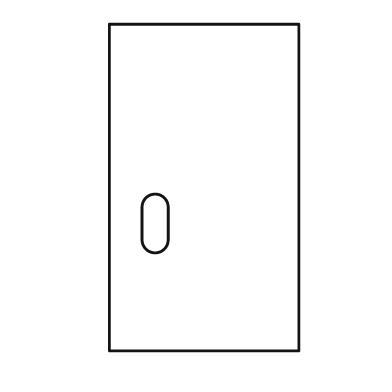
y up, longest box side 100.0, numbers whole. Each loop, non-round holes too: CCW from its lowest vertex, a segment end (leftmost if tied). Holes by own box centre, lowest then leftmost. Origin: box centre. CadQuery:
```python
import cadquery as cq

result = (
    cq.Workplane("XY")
    .moveTo(-29.0, -50.0)
    .lineTo(29.0, -50.0)
    .lineTo(29.0, 50.0)
    .lineTo(-29.0, 50.0)
    .close()
    .moveTo(-19.0, -16.0)
    .threePointArc((-15.0, -20.0), (-11.0, -16.0))
    .lineTo(-11.0, -6.0)
    .threePointArc((-15.0, -2.0), (-19.0, -6.0))
    .close()
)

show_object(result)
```